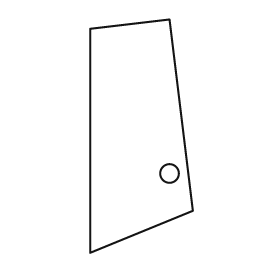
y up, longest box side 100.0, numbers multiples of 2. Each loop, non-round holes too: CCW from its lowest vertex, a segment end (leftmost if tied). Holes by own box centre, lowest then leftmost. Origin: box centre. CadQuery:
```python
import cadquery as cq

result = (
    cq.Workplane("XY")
    .moveTo(-22.0, -50.0)
    .lineTo(22.0, -32.0)
    .lineTo(12.0, 50.0)
    .lineTo(-22.0, 46.0)
    .close()
    .moveTo(12.0, -16.0)
    .circle(4.0)
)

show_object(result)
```